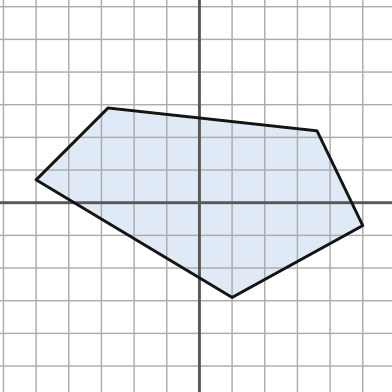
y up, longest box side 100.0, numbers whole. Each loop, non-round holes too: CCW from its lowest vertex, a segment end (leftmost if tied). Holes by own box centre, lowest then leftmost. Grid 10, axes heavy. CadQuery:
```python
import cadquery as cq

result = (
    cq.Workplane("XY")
    .moveTo(10.0, -29.0)
    .lineTo(50.0, -7.0)
    .lineTo(36.0, 22.0)
    .lineTo(-28.0, 29.0)
    .lineTo(-50.0, 7.0)
    .close()
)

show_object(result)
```